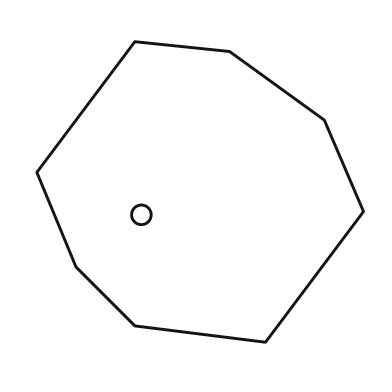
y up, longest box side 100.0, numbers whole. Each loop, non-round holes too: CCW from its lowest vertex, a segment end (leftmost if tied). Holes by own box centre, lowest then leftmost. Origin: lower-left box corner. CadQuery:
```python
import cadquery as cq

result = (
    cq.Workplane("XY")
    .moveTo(70.0, 0.0)
    .lineTo(100.0, 40.0)
    .lineTo(88.0, 68.0)
    .lineTo(59.0, 89.0)
    .lineTo(30.0, 92.0)
    .lineTo(0.0, 52.0)
    .lineTo(12.0, 23.0)
    .lineTo(30.0, 5.0)
    .close()
    .moveTo(32.0, 39.0)
    .circle(3.0)
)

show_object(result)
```